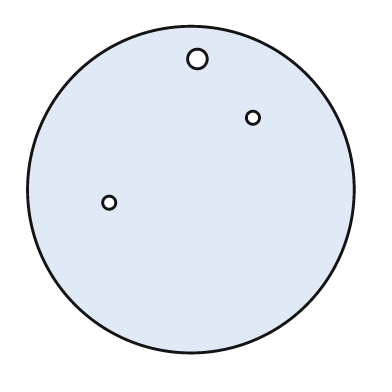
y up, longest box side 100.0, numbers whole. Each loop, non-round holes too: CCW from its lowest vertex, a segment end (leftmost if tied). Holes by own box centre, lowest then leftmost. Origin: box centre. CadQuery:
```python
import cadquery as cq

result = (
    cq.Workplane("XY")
    .moveTo(0.0, 0.0)
    .circle(50.0)
    .moveTo(-25.0, -4.0)
    .circle(2.0)
    .moveTo(19.0, 22.0)
    .circle(2.0)
    .moveTo(2.0, 40.0)
    .circle(3.0)
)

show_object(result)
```